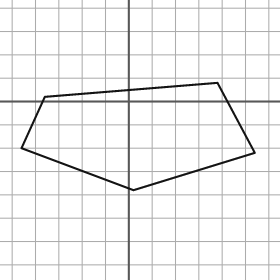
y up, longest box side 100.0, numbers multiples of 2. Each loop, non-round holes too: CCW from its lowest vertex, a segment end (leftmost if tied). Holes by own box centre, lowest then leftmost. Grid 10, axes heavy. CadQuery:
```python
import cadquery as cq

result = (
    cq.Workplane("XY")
    .moveTo(2.0, -38.0)
    .lineTo(54.0, -22.0)
    .lineTo(38.0, 8.0)
    .lineTo(-36.0, 2.0)
    .lineTo(-46.0, -20.0)
    .close()
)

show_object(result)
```